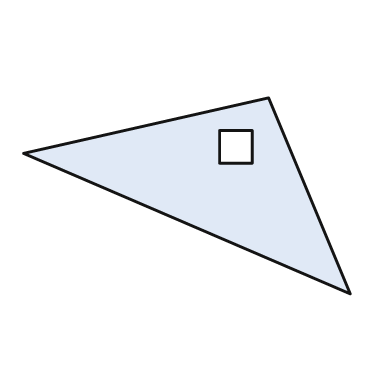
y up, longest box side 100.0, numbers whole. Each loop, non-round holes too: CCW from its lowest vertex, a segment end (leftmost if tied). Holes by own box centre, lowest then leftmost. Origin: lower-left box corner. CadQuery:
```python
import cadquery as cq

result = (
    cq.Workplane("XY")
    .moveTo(100.0, 0.0)
    .lineTo(75.0, 60.0)
    .lineTo(0.0, 43.0)
    .close()
    .moveTo(60.0, 40.0)
    .lineTo(70.0, 40.0)
    .lineTo(70.0, 50.0)
    .lineTo(60.0, 50.0)
    .close()
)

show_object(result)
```